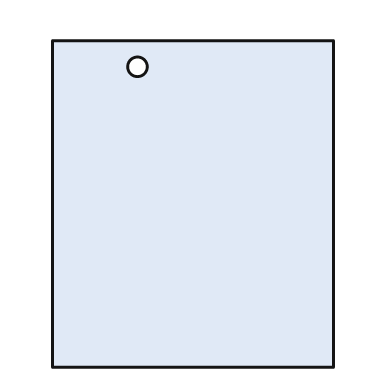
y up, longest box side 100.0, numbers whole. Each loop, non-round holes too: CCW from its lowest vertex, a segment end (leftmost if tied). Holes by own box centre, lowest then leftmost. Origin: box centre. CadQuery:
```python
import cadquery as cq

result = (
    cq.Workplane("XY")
    .moveTo(-43.0, -50.0)
    .lineTo(43.0, -50.0)
    .lineTo(43.0, 50.0)
    .lineTo(-43.0, 50.0)
    .close()
    .moveTo(-17.0, 42.0)
    .circle(3.0)
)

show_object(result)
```